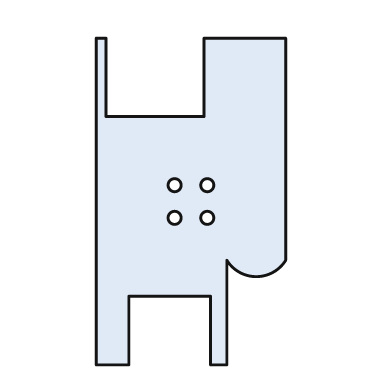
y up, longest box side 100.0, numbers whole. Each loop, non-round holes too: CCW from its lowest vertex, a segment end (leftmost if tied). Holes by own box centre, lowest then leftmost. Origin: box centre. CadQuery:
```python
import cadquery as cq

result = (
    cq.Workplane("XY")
    .moveTo(-29.0, -50.0)
    .lineTo(-19.0, -50.0)
    .lineTo(-19.0, -29.0)
    .lineTo(6.0, -29.0)
    .lineTo(6.0, -50.0)
    .lineTo(11.0, -50.0)
    .lineTo(11.0, -18.0)
    .threePointArc((20.0, -23.0), (29.0, -18.0))
    .lineTo(29.0, 50.0)
    .lineTo(4.0, 50.0)
    .lineTo(4.0, 26.0)
    .lineTo(-26.0, 26.0)
    .lineTo(-26.0, 50.0)
    .lineTo(-29.0, 50.0)
    .close()
    .moveTo(-5.0, -5.0)
    .circle(2.0)
    .moveTo(5.0, -5.0)
    .circle(2.0)
    .moveTo(-5.0, 5.0)
    .circle(2.0)
    .moveTo(5.0, 5.0)
    .circle(2.0)
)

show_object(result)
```